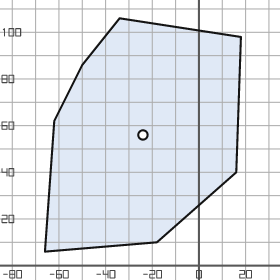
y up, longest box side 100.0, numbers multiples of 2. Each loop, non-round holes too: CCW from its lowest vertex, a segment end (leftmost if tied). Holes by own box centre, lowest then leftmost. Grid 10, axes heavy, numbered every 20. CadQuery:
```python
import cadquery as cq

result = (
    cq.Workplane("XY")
    .moveTo(-66.0, 6.0)
    .lineTo(-18.0, 10.0)
    .lineTo(16.0, 40.0)
    .lineTo(18.0, 98.0)
    .lineTo(-34.0, 106.0)
    .lineTo(-50.0, 86.0)
    .lineTo(-62.0, 62.0)
    .close()
    .moveTo(-24.0, 56.0)
    .circle(2.0)
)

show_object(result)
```